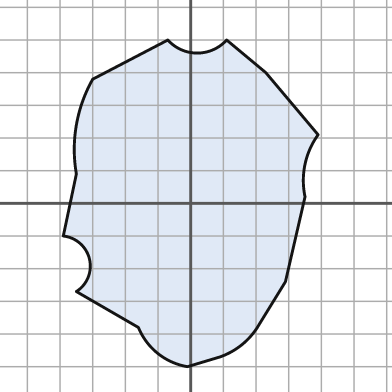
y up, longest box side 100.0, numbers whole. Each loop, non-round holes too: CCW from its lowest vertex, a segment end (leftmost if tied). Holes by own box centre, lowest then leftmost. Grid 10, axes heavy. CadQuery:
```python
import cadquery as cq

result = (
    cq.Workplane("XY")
    .moveTo(-1.0, -50.0)
    .lineTo(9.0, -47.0)
    .threePointArc((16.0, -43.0), (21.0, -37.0))
    .lineTo(29.0, -24.0)
    .lineTo(35.0, 2.0)
    .threePointArc((35.0, 12.0), (39.0, 21.0))
    .lineTo(23.0, 40.0)
    .lineTo(11.0, 50.0)
    .threePointArc((2.0, 46.0), (-7.0, 50.0))
    .lineTo(-30.0, 38.0)
    .threePointArc((-35.0, 24.0), (-35.0, 9.0))
    .lineTo(-39.0, -10.0)
    .threePointArc((-31.0, -17.0), (-35.0, -27.0))
    .lineTo(-16.0, -38.0)
    .threePointArc((-10.0, -46.0), (-1.0, -50.0))
    .close()
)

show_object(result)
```